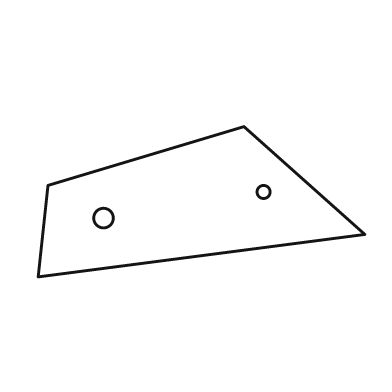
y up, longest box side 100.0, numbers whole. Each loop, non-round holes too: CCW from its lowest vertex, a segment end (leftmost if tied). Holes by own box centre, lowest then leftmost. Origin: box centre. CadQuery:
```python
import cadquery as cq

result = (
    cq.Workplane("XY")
    .moveTo(-50.0, -23.0)
    .lineTo(50.0, -10.0)
    .lineTo(13.0, 23.0)
    .lineTo(-47.0, 5.0)
    .close()
    .moveTo(-30.0, -5.0)
    .circle(3.0)
    .moveTo(19.0, 3.0)
    .circle(2.0)
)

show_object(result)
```